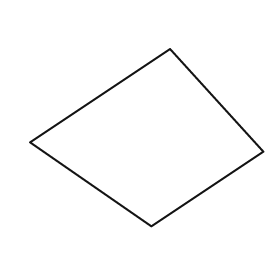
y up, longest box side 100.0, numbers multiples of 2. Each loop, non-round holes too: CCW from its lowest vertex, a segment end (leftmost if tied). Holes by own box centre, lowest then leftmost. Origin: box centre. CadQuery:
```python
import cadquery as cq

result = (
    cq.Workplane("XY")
    .moveTo(2.0, -38.0)
    .lineTo(50.0, -6.0)
    .lineTo(10.0, 38.0)
    .lineTo(-50.0, -2.0)
    .close()
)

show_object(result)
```